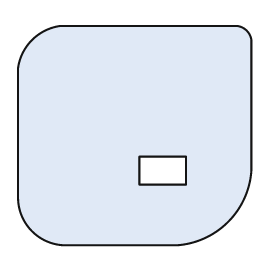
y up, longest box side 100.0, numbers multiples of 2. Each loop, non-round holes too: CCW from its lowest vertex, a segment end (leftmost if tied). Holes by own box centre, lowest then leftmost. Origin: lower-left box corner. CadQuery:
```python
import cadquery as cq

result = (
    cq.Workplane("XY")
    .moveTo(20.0, 0.0)
    .lineTo(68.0, 0.0)
    .threePointArc((90.0, 10.0), (100.0, 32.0))
    .lineTo(100.0, 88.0)
    .threePointArc((98.0, 92.0), (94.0, 94.0))
    .lineTo(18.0, 94.0)
    .threePointArc((6.0, 88.0), (0.0, 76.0))
    .lineTo(0.0, 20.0)
    .threePointArc((6.0, 6.0), (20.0, 0.0))
    .close()
    .moveTo(52.0, 26.0)
    .lineTo(72.0, 26.0)
    .lineTo(72.0, 38.0)
    .lineTo(52.0, 38.0)
    .close()
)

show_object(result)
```